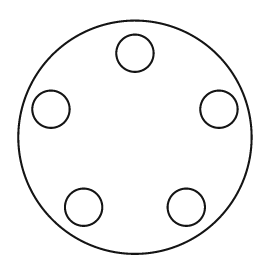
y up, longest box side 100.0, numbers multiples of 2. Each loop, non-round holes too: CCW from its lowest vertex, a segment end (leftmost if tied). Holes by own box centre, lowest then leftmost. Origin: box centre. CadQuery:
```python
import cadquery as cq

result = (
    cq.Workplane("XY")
    .moveTo(0.0, 0.0)
    .circle(50.0)
    .moveTo(-22.0, -30.0)
    .circle(8.0)
    .moveTo(22.0, -30.0)
    .circle(8.0)
    .moveTo(-36.0, 12.0)
    .circle(8.0)
    .moveTo(36.0, 12.0)
    .circle(8.0)
    .moveTo(0.0, 36.0)
    .circle(8.0)
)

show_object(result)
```